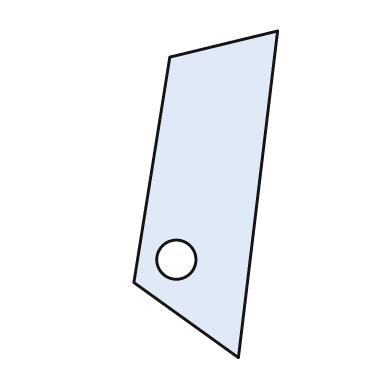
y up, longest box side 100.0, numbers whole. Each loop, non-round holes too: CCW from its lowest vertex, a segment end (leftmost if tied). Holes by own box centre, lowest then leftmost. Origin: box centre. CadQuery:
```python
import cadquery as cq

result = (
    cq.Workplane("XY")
    .moveTo(10.0, -50.0)
    .lineTo(22.0, 50.0)
    .lineTo(-11.0, 42.0)
    .lineTo(-22.0, -27.0)
    .close()
    .moveTo(-9.0, -20.0)
    .circle(6.0)
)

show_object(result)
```